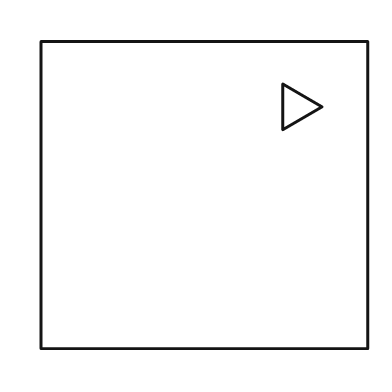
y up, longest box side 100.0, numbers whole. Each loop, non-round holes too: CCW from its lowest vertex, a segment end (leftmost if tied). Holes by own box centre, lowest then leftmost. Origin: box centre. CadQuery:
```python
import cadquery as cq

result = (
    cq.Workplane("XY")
    .moveTo(-50.0, -47.0)
    .lineTo(50.0, -47.0)
    .lineTo(50.0, 47.0)
    .lineTo(-50.0, 47.0)
    .close()
    .moveTo(24.0, 20.0)
    .lineTo(36.0, 27.0)
    .lineTo(24.0, 34.0)
    .close()
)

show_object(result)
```